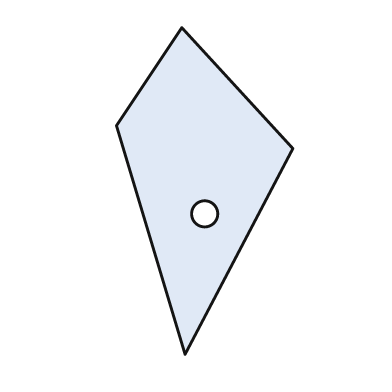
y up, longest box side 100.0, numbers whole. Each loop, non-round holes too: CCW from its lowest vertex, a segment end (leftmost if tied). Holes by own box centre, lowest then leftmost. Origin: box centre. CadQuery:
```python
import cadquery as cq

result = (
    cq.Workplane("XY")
    .moveTo(-6.0, -50.0)
    .lineTo(27.0, 13.0)
    .lineTo(-7.0, 50.0)
    .lineTo(-27.0, 20.0)
    .close()
    .moveTo(0.0, -7.0)
    .circle(4.0)
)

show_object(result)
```